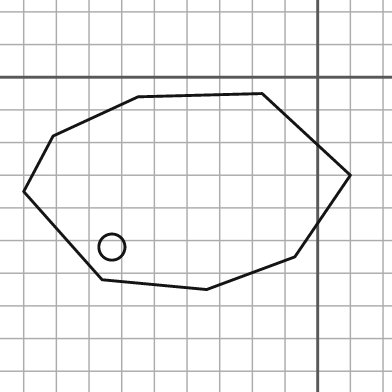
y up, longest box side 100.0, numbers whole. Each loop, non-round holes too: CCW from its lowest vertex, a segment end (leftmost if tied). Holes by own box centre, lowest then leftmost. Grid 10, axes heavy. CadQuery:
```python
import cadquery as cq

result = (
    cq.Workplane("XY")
    .moveTo(-34.0, -65.0)
    .lineTo(-7.0, -55.0)
    .lineTo(10.0, -30.0)
    .lineTo(-17.0, -5.0)
    .lineTo(-55.0, -6.0)
    .lineTo(-81.0, -18.0)
    .lineTo(-90.0, -35.0)
    .lineTo(-66.0, -62.0)
    .close()
    .moveTo(-63.0, -52.0)
    .circle(4.0)
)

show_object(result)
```